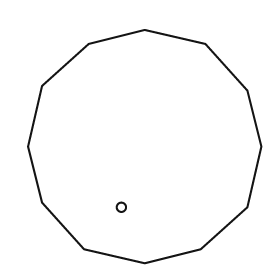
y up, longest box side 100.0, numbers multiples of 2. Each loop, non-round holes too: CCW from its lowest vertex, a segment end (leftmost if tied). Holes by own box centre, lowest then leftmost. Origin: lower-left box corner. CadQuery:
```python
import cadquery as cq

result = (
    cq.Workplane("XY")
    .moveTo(50.0, 0.0)
    .lineTo(74.0, 6.0)
    .lineTo(94.0, 24.0)
    .lineTo(100.0, 50.0)
    .lineTo(94.0, 74.0)
    .lineTo(76.0, 94.0)
    .lineTo(50.0, 100.0)
    .lineTo(26.0, 94.0)
    .lineTo(6.0, 76.0)
    .lineTo(0.0, 50.0)
    .lineTo(6.0, 26.0)
    .lineTo(24.0, 6.0)
    .close()
    .moveTo(40.0, 24.0)
    .circle(2.0)
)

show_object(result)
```